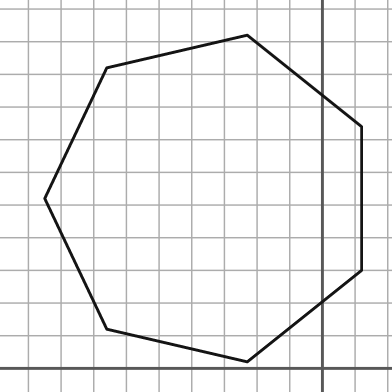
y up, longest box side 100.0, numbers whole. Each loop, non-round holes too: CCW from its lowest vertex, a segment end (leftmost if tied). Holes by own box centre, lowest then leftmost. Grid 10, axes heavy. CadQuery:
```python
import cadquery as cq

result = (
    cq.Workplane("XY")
    .moveTo(-23.0, 2.0)
    .lineTo(12.0, 30.0)
    .lineTo(12.0, 74.0)
    .lineTo(-23.0, 102.0)
    .lineTo(-66.0, 92.0)
    .lineTo(-85.0, 52.0)
    .lineTo(-66.0, 12.0)
    .close()
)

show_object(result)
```